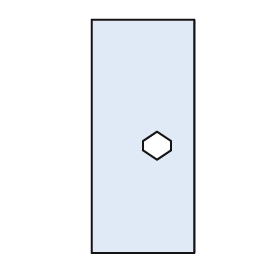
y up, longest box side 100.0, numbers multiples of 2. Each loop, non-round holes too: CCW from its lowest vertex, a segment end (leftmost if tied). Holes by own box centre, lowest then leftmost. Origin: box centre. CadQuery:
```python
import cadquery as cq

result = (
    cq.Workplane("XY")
    .moveTo(-22.0, -50.0)
    .lineTo(22.0, -50.0)
    .lineTo(22.0, 50.0)
    .lineTo(-22.0, 50.0)
    .close()
    .moveTo(6.0, -10.0)
    .lineTo(12.0, -6.0)
    .lineTo(12.0, -2.0)
    .lineTo(6.0, 2.0)
    .lineTo(0.0, -2.0)
    .lineTo(0.0, -6.0)
    .close()
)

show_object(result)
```